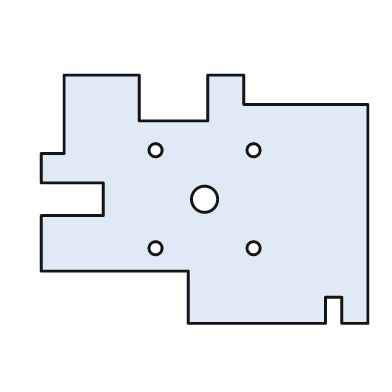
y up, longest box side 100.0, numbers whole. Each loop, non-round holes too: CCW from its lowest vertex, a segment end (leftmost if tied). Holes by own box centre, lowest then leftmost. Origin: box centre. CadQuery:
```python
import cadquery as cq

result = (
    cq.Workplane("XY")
    .moveTo(-5.0, -38.0)
    .lineTo(37.0, -38.0)
    .lineTo(37.0, -30.0)
    .lineTo(42.0, -30.0)
    .lineTo(42.0, -38.0)
    .lineTo(50.0, -38.0)
    .lineTo(50.0, 29.0)
    .lineTo(12.0, 29.0)
    .lineTo(12.0, 38.0)
    .lineTo(1.0, 38.0)
    .lineTo(1.0, 24.0)
    .lineTo(-20.0, 24.0)
    .lineTo(-20.0, 38.0)
    .lineTo(-43.0, 38.0)
    .lineTo(-43.0, 14.0)
    .lineTo(-50.0, 14.0)
    .lineTo(-50.0, 5.0)
    .lineTo(-31.0, 5.0)
    .lineTo(-31.0, -5.0)
    .lineTo(-50.0, -5.0)
    .lineTo(-50.0, -22.0)
    .lineTo(-5.0, -22.0)
    .close()
    .moveTo(-15.0, -15.0)
    .circle(2.0)
    .moveTo(15.0, -15.0)
    .circle(2.0)
    .moveTo(0.0, 0.0)
    .circle(4.0)
    .moveTo(-15.0, 15.0)
    .circle(2.0)
    .moveTo(15.0, 15.0)
    .circle(2.0)
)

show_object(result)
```